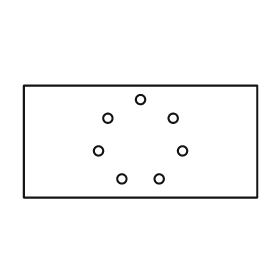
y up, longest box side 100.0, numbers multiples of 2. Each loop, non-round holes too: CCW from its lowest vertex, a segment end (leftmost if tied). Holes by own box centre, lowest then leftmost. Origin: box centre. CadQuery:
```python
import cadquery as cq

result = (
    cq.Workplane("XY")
    .moveTo(-50.0, -24.0)
    .lineTo(50.0, -24.0)
    .lineTo(50.0, 24.0)
    .lineTo(-50.0, 24.0)
    .close()
    .moveTo(-8.0, -16.0)
    .circle(2.0)
    .moveTo(8.0, -16.0)
    .circle(2.0)
    .moveTo(-18.0, -4.0)
    .circle(2.0)
    .moveTo(18.0, -4.0)
    .circle(2.0)
    .moveTo(-14.0, 10.0)
    .circle(2.0)
    .moveTo(14.0, 10.0)
    .circle(2.0)
    .moveTo(0.0, 18.0)
    .circle(2.0)
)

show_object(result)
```